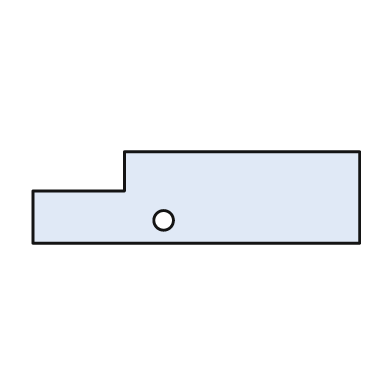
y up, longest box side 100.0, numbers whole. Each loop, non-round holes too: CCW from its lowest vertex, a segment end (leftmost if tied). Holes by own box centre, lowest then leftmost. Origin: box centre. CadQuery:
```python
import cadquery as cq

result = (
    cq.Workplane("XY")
    .moveTo(-50.0, -14.0)
    .lineTo(50.0, -14.0)
    .lineTo(50.0, 14.0)
    .lineTo(-22.0, 14.0)
    .lineTo(-22.0, 2.0)
    .lineTo(-50.0, 2.0)
    .close()
    .moveTo(-10.0, -7.0)
    .circle(3.0)
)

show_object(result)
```